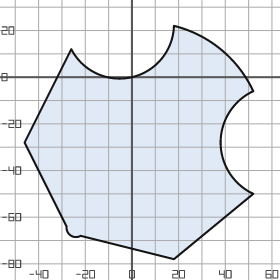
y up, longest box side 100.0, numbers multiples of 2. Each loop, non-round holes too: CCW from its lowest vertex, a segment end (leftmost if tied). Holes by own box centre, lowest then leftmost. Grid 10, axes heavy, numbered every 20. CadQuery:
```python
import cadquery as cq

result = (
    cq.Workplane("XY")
    .moveTo(18.0, -78.0)
    .lineTo(52.0, -50.0)
    .threePointArc((38.0, -28.0), (52.0, -6.0))
    .threePointArc((38.0, 12.0), (18.0, 22.0))
    .threePointArc((0.0, 0.0), (-26.0, 12.0))
    .lineTo(-46.0, -28.0)
    .lineTo(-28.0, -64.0)
    .threePointArc((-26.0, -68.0), (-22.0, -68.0))
    .close()
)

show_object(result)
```